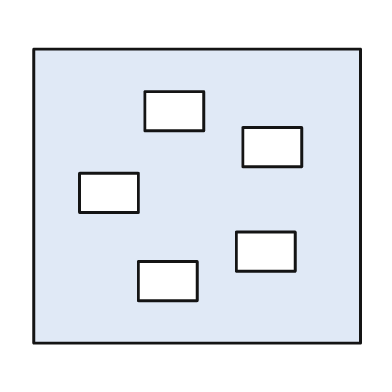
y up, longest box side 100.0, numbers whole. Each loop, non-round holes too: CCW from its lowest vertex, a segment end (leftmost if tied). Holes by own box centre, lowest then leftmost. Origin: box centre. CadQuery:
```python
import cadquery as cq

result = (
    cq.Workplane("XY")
    .moveTo(-50.0, -45.0)
    .lineTo(50.0, -45.0)
    .lineTo(50.0, 45.0)
    .lineTo(-50.0, 45.0)
    .close()
    .moveTo(-18.0, -32.0)
    .lineTo(0.0, -32.0)
    .lineTo(0.0, -20.0)
    .lineTo(-18.0, -20.0)
    .close()
    .moveTo(12.0, -23.0)
    .lineTo(30.0, -23.0)
    .lineTo(30.0, -11.0)
    .lineTo(12.0, -11.0)
    .close()
    .moveTo(-36.0, -5.0)
    .lineTo(-18.0, -5.0)
    .lineTo(-18.0, 7.0)
    .lineTo(-36.0, 7.0)
    .close()
    .moveTo(14.0, 9.0)
    .lineTo(32.0, 9.0)
    .lineTo(32.0, 21.0)
    .lineTo(14.0, 21.0)
    .close()
    .moveTo(-16.0, 20.0)
    .lineTo(2.0, 20.0)
    .lineTo(2.0, 32.0)
    .lineTo(-16.0, 32.0)
    .close()
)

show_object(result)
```